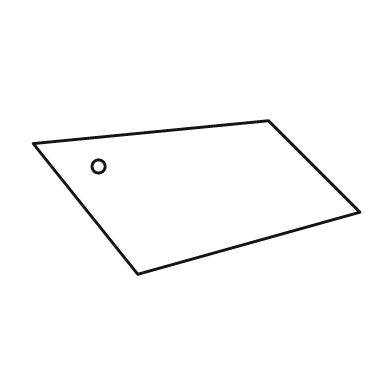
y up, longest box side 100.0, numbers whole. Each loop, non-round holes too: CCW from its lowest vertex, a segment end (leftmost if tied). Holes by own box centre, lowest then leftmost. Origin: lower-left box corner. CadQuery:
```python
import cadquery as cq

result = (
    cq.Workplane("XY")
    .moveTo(32.0, 0.0)
    .lineTo(100.0, 19.0)
    .lineTo(72.0, 47.0)
    .lineTo(0.0, 40.0)
    .close()
    .moveTo(20.0, 33.0)
    .circle(2.0)
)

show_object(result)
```